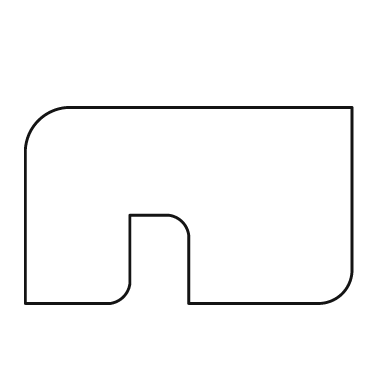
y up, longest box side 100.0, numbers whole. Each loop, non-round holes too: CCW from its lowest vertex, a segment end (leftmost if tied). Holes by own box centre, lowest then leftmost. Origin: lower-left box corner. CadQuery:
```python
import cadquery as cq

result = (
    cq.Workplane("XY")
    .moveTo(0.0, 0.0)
    .lineTo(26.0, 0.0)
    .threePointArc((30.0, 2.0), (32.0, 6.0))
    .lineTo(32.0, 27.0)
    .lineTo(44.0, 27.0)
    .threePointArc((48.0, 25.0), (50.0, 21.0))
    .lineTo(50.0, 0.0)
    .lineTo(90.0, 0.0)
    .threePointArc((97.0, 3.0), (100.0, 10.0))
    .lineTo(100.0, 60.0)
    .lineTo(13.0, 60.0)
    .threePointArc((4.0, 56.0), (0.0, 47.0))
    .close()
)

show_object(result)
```